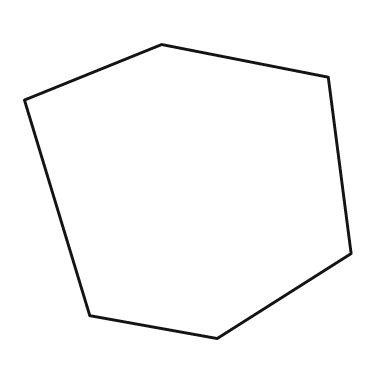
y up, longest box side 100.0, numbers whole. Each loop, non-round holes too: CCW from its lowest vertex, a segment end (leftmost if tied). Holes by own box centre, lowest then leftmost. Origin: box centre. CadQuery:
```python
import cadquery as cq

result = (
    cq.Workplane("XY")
    .moveTo(9.0, -45.0)
    .lineTo(50.0, -19.0)
    .lineTo(43.0, 35.0)
    .lineTo(-8.0, 45.0)
    .lineTo(-50.0, 28.0)
    .lineTo(-30.0, -38.0)
    .close()
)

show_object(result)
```